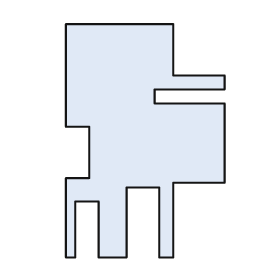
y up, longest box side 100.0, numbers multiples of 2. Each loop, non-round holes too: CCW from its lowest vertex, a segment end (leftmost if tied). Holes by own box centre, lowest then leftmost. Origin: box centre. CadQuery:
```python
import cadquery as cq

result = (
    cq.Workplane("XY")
    .moveTo(-34.0, -50.0)
    .lineTo(-30.0, -50.0)
    .lineTo(-30.0, -26.0)
    .lineTo(-20.0, -26.0)
    .lineTo(-20.0, -50.0)
    .lineTo(-8.0, -50.0)
    .lineTo(-8.0, -20.0)
    .lineTo(6.0, -20.0)
    .lineTo(6.0, -50.0)
    .lineTo(12.0, -50.0)
    .lineTo(12.0, -18.0)
    .lineTo(34.0, -18.0)
    .lineTo(34.0, 16.0)
    .lineTo(4.0, 16.0)
    .lineTo(4.0, 22.0)
    .lineTo(34.0, 22.0)
    .lineTo(34.0, 28.0)
    .lineTo(12.0, 28.0)
    .lineTo(12.0, 50.0)
    .lineTo(-34.0, 50.0)
    .lineTo(-34.0, 6.0)
    .lineTo(-24.0, 6.0)
    .lineTo(-24.0, -16.0)
    .lineTo(-34.0, -16.0)
    .close()
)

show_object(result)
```